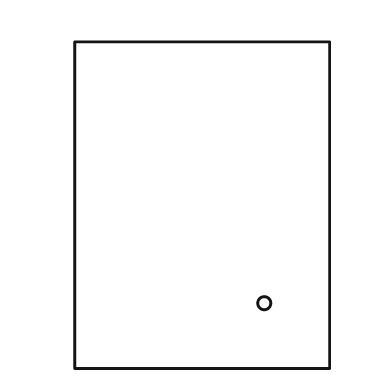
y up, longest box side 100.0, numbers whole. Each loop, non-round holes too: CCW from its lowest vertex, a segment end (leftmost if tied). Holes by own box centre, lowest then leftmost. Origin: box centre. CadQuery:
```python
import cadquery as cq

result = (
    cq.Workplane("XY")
    .moveTo(-39.0, -50.0)
    .lineTo(39.0, -50.0)
    .lineTo(39.0, 50.0)
    .lineTo(-39.0, 50.0)
    .close()
    .moveTo(19.0, -30.0)
    .circle(2.0)
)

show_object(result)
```